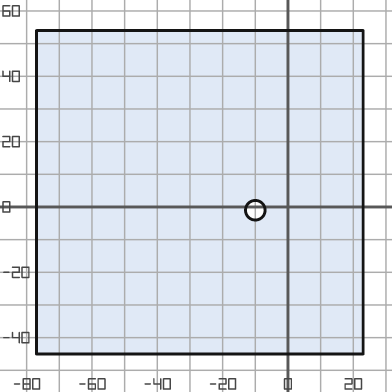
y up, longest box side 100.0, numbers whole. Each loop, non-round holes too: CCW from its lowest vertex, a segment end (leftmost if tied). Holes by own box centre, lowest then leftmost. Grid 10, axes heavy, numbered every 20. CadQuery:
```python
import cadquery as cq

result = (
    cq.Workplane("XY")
    .moveTo(-77.0, -45.0)
    .lineTo(23.0, -45.0)
    .lineTo(23.0, 54.0)
    .lineTo(-77.0, 54.0)
    .close()
    .moveTo(-10.0, -1.0)
    .circle(3.0)
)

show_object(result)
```